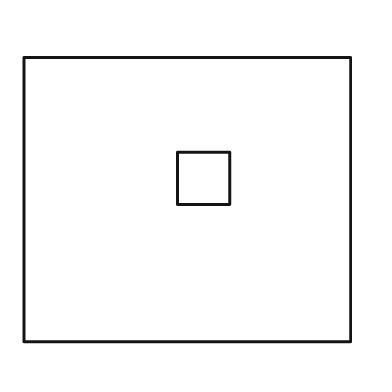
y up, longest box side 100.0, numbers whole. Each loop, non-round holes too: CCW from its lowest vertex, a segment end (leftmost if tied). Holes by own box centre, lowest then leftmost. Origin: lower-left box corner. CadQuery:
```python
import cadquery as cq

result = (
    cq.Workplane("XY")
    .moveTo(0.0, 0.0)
    .lineTo(100.0, 0.0)
    .lineTo(100.0, 87.0)
    .lineTo(0.0, 87.0)
    .close()
    .moveTo(47.0, 42.0)
    .lineTo(63.0, 42.0)
    .lineTo(63.0, 58.0)
    .lineTo(47.0, 58.0)
    .close()
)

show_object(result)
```